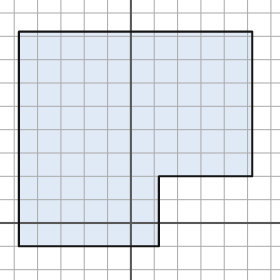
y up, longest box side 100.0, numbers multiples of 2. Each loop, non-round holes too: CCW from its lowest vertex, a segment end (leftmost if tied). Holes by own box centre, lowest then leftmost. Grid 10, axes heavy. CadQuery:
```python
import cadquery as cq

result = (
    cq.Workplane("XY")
    .moveTo(-48.0, -10.0)
    .lineTo(12.0, -10.0)
    .lineTo(12.0, 20.0)
    .lineTo(52.0, 20.0)
    .lineTo(52.0, 82.0)
    .lineTo(-48.0, 82.0)
    .close()
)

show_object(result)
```